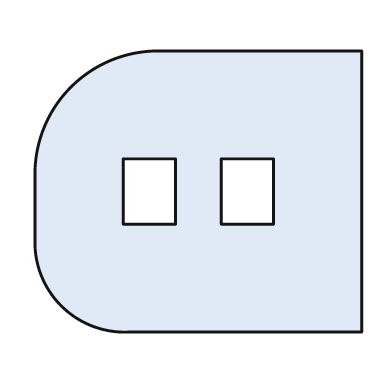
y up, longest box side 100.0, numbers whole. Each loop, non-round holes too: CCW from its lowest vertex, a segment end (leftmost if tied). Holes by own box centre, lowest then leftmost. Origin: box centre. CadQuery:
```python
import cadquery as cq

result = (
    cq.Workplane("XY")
    .moveTo(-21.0, -43.0)
    .lineTo(50.0, -43.0)
    .lineTo(50.0, 43.0)
    .lineTo(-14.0, 43.0)
    .threePointArc((-39.0, 32.0), (-50.0, 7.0))
    .lineTo(-50.0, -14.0)
    .threePointArc((-42.0, -35.0), (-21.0, -43.0))
    .close()
    .moveTo(-23.0, -10.0)
    .lineTo(-7.0, -10.0)
    .lineTo(-7.0, 10.0)
    .lineTo(-23.0, 10.0)
    .close()
    .moveTo(7.0, -10.0)
    .lineTo(23.0, -10.0)
    .lineTo(23.0, 10.0)
    .lineTo(7.0, 10.0)
    .close()
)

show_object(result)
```